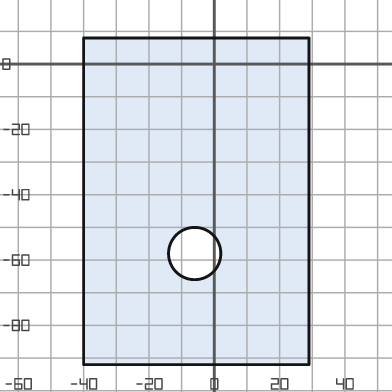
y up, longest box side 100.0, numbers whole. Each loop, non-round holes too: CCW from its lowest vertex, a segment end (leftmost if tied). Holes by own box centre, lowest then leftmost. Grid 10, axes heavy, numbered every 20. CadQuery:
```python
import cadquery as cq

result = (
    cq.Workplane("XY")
    .moveTo(-40.0, -92.0)
    .lineTo(29.0, -92.0)
    .lineTo(29.0, 8.0)
    .lineTo(-40.0, 8.0)
    .close()
    .moveTo(-6.0, -58.0)
    .circle(8.0)
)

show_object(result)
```